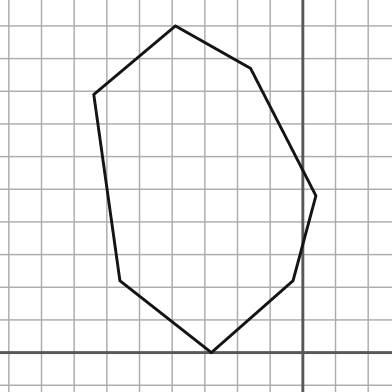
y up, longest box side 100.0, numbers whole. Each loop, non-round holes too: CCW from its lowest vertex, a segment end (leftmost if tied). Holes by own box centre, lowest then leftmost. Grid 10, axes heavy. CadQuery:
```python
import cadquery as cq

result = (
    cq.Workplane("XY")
    .moveTo(-28.0, 0.0)
    .lineTo(-3.0, 22.0)
    .lineTo(4.0, 48.0)
    .lineTo(-16.0, 87.0)
    .lineTo(-39.0, 100.0)
    .lineTo(-64.0, 79.0)
    .lineTo(-56.0, 22.0)
    .close()
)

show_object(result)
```